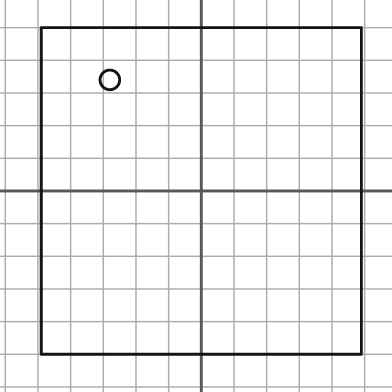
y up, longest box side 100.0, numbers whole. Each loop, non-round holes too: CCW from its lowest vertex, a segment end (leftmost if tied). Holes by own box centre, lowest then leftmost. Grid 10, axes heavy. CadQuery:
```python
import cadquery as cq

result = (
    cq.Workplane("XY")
    .moveTo(-49.0, -50.0)
    .lineTo(49.0, -50.0)
    .lineTo(49.0, 50.0)
    .lineTo(-49.0, 50.0)
    .close()
    .moveTo(-28.0, 34.0)
    .circle(3.0)
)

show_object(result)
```